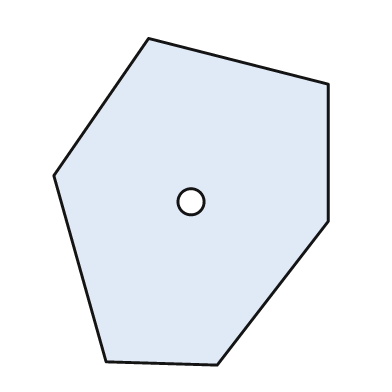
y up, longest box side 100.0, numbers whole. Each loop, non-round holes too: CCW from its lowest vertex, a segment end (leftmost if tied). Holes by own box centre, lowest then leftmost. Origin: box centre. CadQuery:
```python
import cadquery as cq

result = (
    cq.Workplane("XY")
    .moveTo(8.0, -50.0)
    .lineTo(42.0, -6.0)
    .lineTo(42.0, 36.0)
    .lineTo(-13.0, 50.0)
    .lineTo(-42.0, 8.0)
    .lineTo(-26.0, -49.0)
    .close()
    .moveTo(0.0, 0.0)
    .circle(4.0)
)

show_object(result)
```